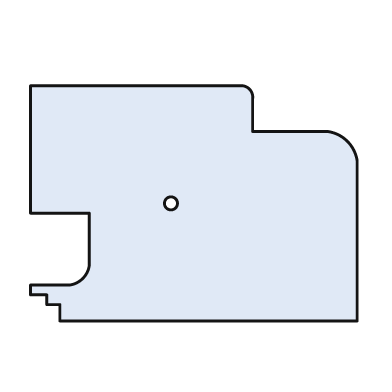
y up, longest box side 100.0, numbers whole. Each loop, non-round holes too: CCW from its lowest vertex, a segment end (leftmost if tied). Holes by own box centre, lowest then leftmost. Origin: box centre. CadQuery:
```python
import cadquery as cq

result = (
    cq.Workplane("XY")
    .moveTo(-41.0, -36.0)
    .lineTo(50.0, -36.0)
    .lineTo(50.0, 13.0)
    .threePointArc((47.0, 19.0), (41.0, 22.0))
    .lineTo(18.0, 22.0)
    .lineTo(18.0, 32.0)
    .threePointArc((17.0, 35.0), (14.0, 36.0))
    .lineTo(-50.0, 36.0)
    .lineTo(-50.0, -3.0)
    .lineTo(-32.0, -3.0)
    .lineTo(-32.0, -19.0)
    .threePointArc((-34.0, -23.0), (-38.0, -25.0))
    .lineTo(-50.0, -25.0)
    .lineTo(-50.0, -28.0)
    .lineTo(-45.0, -28.0)
    .lineTo(-45.0, -31.0)
    .lineTo(-41.0, -31.0)
    .close()
    .moveTo(-7.0, 0.0)
    .circle(2.0)
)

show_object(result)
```